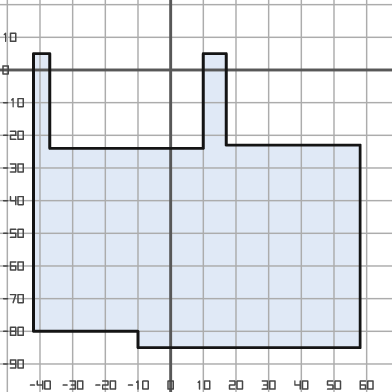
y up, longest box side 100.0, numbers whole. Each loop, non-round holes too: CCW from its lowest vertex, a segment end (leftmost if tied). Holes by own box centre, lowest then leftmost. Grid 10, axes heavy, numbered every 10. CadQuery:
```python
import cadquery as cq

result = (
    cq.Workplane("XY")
    .moveTo(-10.0, -85.0)
    .lineTo(58.0, -85.0)
    .lineTo(58.0, -23.0)
    .lineTo(17.0, -23.0)
    .lineTo(17.0, 5.0)
    .lineTo(10.0, 5.0)
    .lineTo(10.0, -24.0)
    .lineTo(-37.0, -24.0)
    .lineTo(-37.0, 5.0)
    .lineTo(-42.0, 5.0)
    .lineTo(-42.0, -80.0)
    .lineTo(-10.0, -80.0)
    .close()
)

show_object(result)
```